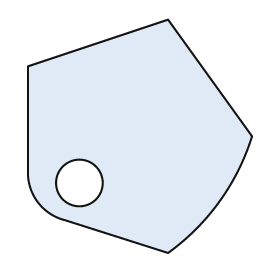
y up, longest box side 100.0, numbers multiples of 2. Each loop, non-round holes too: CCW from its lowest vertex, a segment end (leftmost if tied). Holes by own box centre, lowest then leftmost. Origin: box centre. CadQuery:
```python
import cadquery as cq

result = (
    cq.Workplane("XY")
    .moveTo(12.0, -50.0)
    .threePointArc((34.0, -28.0), (48.0, 0.0))
    .lineTo(12.0, 50.0)
    .lineTo(-48.0, 30.0)
    .lineTo(-48.0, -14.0)
    .threePointArc((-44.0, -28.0), (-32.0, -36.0))
    .close()
    .moveTo(-26.0, -20.0)
    .circle(10.0)
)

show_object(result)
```